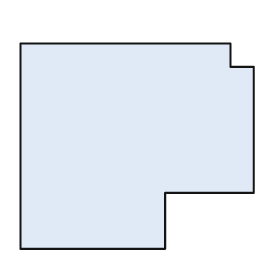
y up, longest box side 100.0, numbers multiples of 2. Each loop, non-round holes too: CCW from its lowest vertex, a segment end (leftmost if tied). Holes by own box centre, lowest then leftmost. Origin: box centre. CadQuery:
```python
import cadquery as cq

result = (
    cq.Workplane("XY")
    .moveTo(-50.0, -44.0)
    .lineTo(12.0, -44.0)
    .lineTo(12.0, -20.0)
    .lineTo(50.0, -20.0)
    .lineTo(50.0, 34.0)
    .lineTo(40.0, 34.0)
    .lineTo(40.0, 44.0)
    .lineTo(-50.0, 44.0)
    .close()
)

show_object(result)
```